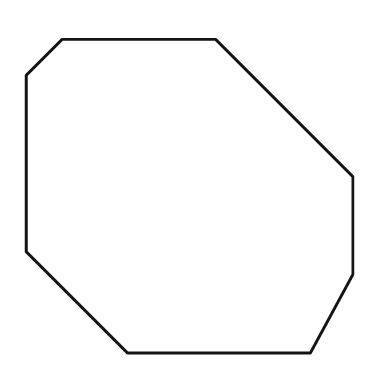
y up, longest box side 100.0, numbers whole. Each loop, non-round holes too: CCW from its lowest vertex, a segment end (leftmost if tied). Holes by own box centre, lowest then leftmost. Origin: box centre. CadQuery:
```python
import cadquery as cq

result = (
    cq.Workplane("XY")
    .moveTo(-19.0, -48.0)
    .lineTo(37.0, -48.0)
    .lineTo(50.0, -24.0)
    .lineTo(50.0, 6.0)
    .lineTo(8.0, 48.0)
    .lineTo(-39.0, 48.0)
    .lineTo(-50.0, 37.0)
    .lineTo(-50.0, -17.0)
    .close()
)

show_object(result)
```